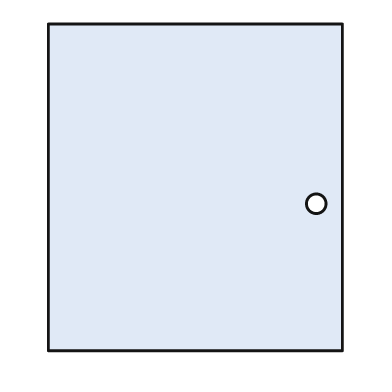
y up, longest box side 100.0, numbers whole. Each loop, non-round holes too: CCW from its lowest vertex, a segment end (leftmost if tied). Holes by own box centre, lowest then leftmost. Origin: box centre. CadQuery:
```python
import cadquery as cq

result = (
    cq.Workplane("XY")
    .moveTo(-45.0, -50.0)
    .lineTo(45.0, -50.0)
    .lineTo(45.0, 50.0)
    .lineTo(-45.0, 50.0)
    .close()
    .moveTo(37.0, -5.0)
    .circle(3.0)
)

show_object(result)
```